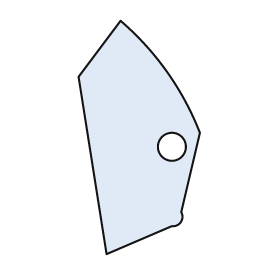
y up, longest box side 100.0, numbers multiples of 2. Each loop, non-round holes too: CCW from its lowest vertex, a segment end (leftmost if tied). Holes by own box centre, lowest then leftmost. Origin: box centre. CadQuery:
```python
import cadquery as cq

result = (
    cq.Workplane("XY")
    .moveTo(-14.0, -50.0)
    .lineTo(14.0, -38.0)
    .threePointArc((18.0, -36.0), (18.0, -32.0))
    .lineTo(26.0, 2.0)
    .threePointArc((12.0, 28.0), (-8.0, 50.0))
    .lineTo(-26.0, 26.0)
    .close()
    .moveTo(14.0, -4.0)
    .circle(6.0)
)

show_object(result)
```